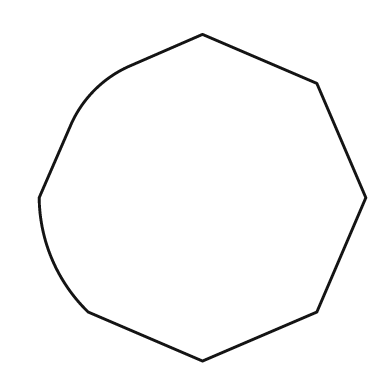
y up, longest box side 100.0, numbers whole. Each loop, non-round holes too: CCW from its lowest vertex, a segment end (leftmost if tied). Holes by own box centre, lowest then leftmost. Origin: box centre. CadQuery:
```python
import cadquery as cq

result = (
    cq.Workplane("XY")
    .moveTo(0.0, -50.0)
    .lineTo(35.0, -35.0)
    .lineTo(50.0, 0.0)
    .lineTo(35.0, 35.0)
    .lineTo(0.0, 50.0)
    .lineTo(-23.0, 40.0)
    .threePointArc((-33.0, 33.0), (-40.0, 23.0))
    .lineTo(-50.0, 0.0)
    .threePointArc((-46.0, -19.0), (-35.0, -35.0))
    .close()
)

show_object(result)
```